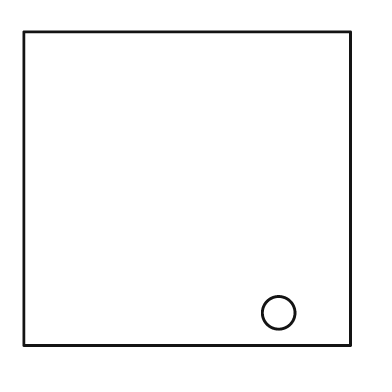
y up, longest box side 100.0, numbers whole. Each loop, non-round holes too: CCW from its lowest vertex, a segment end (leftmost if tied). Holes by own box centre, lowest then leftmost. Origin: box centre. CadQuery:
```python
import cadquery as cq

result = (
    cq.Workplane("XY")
    .moveTo(-50.0, -48.0)
    .lineTo(50.0, -48.0)
    .lineTo(50.0, 48.0)
    .lineTo(-50.0, 48.0)
    .close()
    .moveTo(28.0, -38.0)
    .circle(5.0)
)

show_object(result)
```